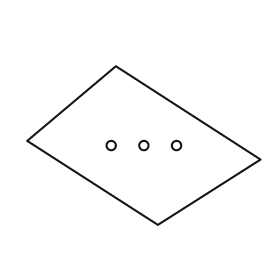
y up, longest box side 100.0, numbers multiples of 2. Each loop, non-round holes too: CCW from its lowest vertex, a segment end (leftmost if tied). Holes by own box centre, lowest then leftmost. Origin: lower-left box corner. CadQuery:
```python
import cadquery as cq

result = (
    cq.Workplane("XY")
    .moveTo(56.0, 0.0)
    .lineTo(100.0, 28.0)
    .lineTo(38.0, 68.0)
    .lineTo(0.0, 36.0)
    .close()
    .moveTo(36.0, 34.0)
    .circle(2.0)
    .moveTo(50.0, 34.0)
    .circle(2.0)
    .moveTo(64.0, 34.0)
    .circle(2.0)
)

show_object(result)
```